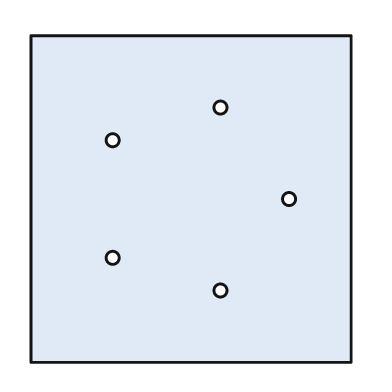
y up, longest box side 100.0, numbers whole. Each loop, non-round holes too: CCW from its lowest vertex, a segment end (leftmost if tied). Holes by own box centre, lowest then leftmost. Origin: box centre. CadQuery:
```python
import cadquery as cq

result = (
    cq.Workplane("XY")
    .moveTo(-49.0, -50.0)
    .lineTo(49.0, -50.0)
    .lineTo(49.0, 50.0)
    .lineTo(-49.0, 50.0)
    .close()
    .moveTo(9.0, -28.0)
    .circle(2.0)
    .moveTo(-24.0, -18.0)
    .circle(2.0)
    .moveTo(30.0, 0.0)
    .circle(2.0)
    .moveTo(-24.0, 18.0)
    .circle(2.0)
    .moveTo(9.0, 28.0)
    .circle(2.0)
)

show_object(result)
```